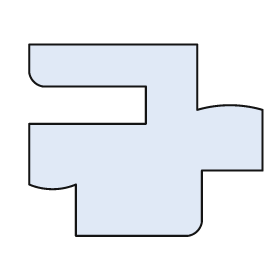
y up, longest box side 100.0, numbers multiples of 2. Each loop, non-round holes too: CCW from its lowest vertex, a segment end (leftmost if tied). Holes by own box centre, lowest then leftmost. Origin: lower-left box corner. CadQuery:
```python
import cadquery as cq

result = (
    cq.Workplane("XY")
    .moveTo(20.0, 0.0)
    .lineTo(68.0, 0.0)
    .threePointArc((72.0, 2.0), (74.0, 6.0))
    .lineTo(74.0, 28.0)
    .lineTo(100.0, 28.0)
    .lineTo(100.0, 54.0)
    .threePointArc((86.0, 56.0), (72.0, 54.0))
    .lineTo(72.0, 82.0)
    .lineTo(0.0, 82.0)
    .lineTo(0.0, 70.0)
    .threePointArc((2.0, 66.0), (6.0, 64.0))
    .lineTo(50.0, 64.0)
    .lineTo(50.0, 48.0)
    .lineTo(0.0, 48.0)
    .lineTo(0.0, 22.0)
    .threePointArc((10.0, 20.0), (20.0, 22.0))
    .close()
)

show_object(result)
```